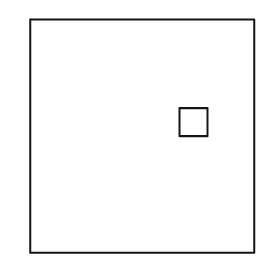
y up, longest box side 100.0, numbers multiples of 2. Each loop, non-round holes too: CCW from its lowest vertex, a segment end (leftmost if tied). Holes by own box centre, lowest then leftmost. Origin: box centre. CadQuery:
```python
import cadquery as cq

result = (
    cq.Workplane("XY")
    .moveTo(-48.0, -50.0)
    .lineTo(48.0, -50.0)
    .lineTo(48.0, 50.0)
    .lineTo(-48.0, 50.0)
    .close()
    .moveTo(16.0, 0.0)
    .lineTo(28.0, 0.0)
    .lineTo(28.0, 12.0)
    .lineTo(16.0, 12.0)
    .close()
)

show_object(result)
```